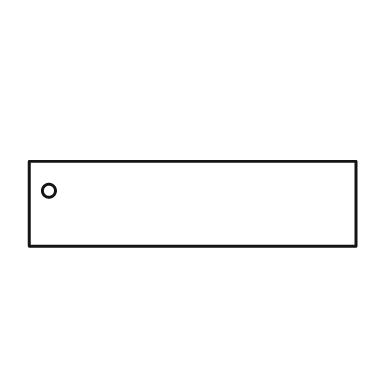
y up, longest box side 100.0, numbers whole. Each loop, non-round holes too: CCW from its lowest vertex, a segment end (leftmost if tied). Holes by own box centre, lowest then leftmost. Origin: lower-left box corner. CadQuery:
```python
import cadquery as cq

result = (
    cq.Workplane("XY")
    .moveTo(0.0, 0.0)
    .lineTo(100.0, 0.0)
    .lineTo(100.0, 26.0)
    .lineTo(0.0, 26.0)
    .close()
    .moveTo(6.0, 17.0)
    .circle(2.0)
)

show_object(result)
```